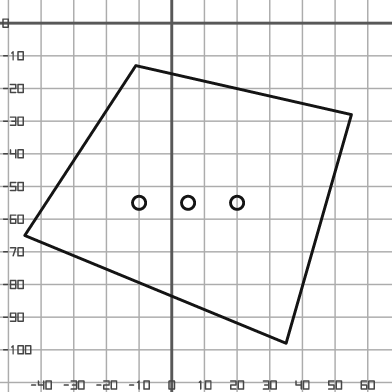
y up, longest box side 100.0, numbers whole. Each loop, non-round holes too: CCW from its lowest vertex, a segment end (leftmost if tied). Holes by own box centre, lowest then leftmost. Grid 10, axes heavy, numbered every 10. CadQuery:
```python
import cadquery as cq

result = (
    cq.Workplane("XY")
    .moveTo(35.0, -98.0)
    .lineTo(55.0, -28.0)
    .lineTo(-11.0, -13.0)
    .lineTo(-45.0, -65.0)
    .close()
    .moveTo(-10.0, -55.0)
    .circle(2.0)
    .moveTo(5.0, -55.0)
    .circle(2.0)
    .moveTo(20.0, -55.0)
    .circle(2.0)
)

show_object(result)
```